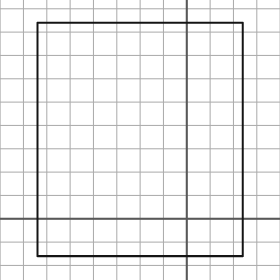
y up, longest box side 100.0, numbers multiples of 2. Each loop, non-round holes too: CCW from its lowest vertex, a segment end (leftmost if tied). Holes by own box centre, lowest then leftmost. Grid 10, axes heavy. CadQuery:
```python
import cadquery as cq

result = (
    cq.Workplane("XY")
    .moveTo(-64.0, -16.0)
    .lineTo(24.0, -16.0)
    .lineTo(24.0, 84.0)
    .lineTo(-64.0, 84.0)
    .close()
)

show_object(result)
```